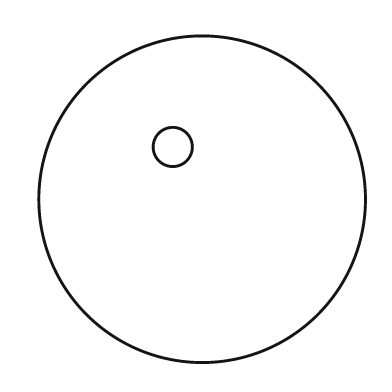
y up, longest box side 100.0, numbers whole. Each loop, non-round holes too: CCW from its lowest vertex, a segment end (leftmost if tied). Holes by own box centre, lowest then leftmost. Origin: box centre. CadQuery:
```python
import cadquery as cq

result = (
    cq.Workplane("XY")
    .moveTo(0.0, 0.0)
    .circle(50.0)
    .moveTo(-9.0, 16.0)
    .circle(6.0)
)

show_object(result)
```